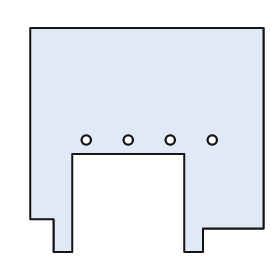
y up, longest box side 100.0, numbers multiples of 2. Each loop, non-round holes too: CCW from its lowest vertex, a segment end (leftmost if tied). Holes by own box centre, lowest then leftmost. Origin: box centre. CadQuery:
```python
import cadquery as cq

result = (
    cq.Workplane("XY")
    .moveTo(-40.0, -48.0)
    .lineTo(-32.0, -48.0)
    .lineTo(-32.0, -6.0)
    .lineTo(16.0, -6.0)
    .lineTo(16.0, -48.0)
    .lineTo(24.0, -48.0)
    .lineTo(24.0, -38.0)
    .lineTo(50.0, -38.0)
    .lineTo(50.0, 48.0)
    .lineTo(-50.0, 48.0)
    .lineTo(-50.0, -34.0)
    .lineTo(-40.0, -34.0)
    .close()
    .moveTo(-26.0, 0.0)
    .circle(2.0)
    .moveTo(-8.0, 0.0)
    .circle(2.0)
    .moveTo(10.0, 0.0)
    .circle(2.0)
    .moveTo(28.0, 0.0)
    .circle(2.0)
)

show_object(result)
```